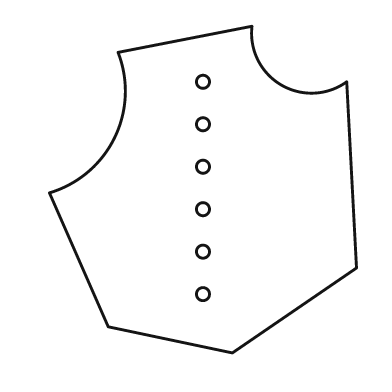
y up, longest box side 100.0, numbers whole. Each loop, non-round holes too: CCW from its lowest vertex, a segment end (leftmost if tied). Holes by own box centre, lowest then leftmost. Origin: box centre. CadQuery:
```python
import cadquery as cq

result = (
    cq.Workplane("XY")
    .moveTo(9.0, -50.0)
    .lineTo(47.0, -24.0)
    .lineTo(44.0, 33.0)
    .threePointArc((24.0, 32.0), (15.0, 50.0))
    .lineTo(-26.0, 42.0)
    .threePointArc((-27.0, 16.0), (-47.0, -1.0))
    .lineTo(-29.0, -42.0)
    .close()
    .moveTo(0.0, -32.0)
    .circle(2.0)
    .moveTo(0.0, -19.0)
    .circle(2.0)
    .moveTo(0.0, -6.0)
    .circle(2.0)
    .moveTo(0.0, 7.0)
    .circle(2.0)
    .moveTo(0.0, 20.0)
    .circle(2.0)
    .moveTo(0.0, 33.0)
    .circle(2.0)
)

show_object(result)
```